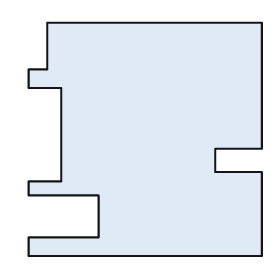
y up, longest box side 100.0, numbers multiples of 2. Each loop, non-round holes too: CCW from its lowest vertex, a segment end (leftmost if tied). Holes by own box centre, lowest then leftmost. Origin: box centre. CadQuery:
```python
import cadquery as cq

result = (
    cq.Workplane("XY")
    .moveTo(-50.0, -50.0)
    .lineTo(50.0, -50.0)
    .lineTo(50.0, -14.0)
    .lineTo(30.0, -14.0)
    .lineTo(30.0, -4.0)
    .lineTo(50.0, -4.0)
    .lineTo(50.0, 50.0)
    .lineTo(-42.0, 50.0)
    .lineTo(-42.0, 30.0)
    .lineTo(-50.0, 30.0)
    .lineTo(-50.0, 22.0)
    .lineTo(-36.0, 22.0)
    .lineTo(-36.0, -18.0)
    .lineTo(-50.0, -18.0)
    .lineTo(-50.0, -24.0)
    .lineTo(-20.0, -24.0)
    .lineTo(-20.0, -42.0)
    .lineTo(-50.0, -42.0)
    .close()
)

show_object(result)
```